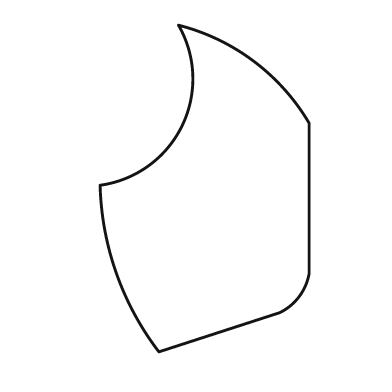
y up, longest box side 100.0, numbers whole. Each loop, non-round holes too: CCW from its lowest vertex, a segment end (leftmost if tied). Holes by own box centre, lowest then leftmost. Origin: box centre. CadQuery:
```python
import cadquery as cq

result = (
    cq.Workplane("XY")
    .moveTo(-14.0, -50.0)
    .lineTo(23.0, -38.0)
    .threePointArc((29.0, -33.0), (32.0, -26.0))
    .lineTo(32.0, 20.0)
    .threePointArc((15.0, 39.0), (-8.0, 50.0))
    .threePointArc((-7.0, 19.0), (-32.0, 1.0))
    .threePointArc((-27.0, -26.0), (-14.0, -50.0))
    .close()
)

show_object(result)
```